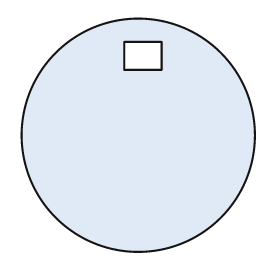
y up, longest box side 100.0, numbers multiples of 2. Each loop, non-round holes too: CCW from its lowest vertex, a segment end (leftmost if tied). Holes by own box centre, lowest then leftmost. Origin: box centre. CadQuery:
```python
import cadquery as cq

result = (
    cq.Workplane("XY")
    .moveTo(0.0, 0.0)
    .circle(50.0)
    .moveTo(-6.0, 28.0)
    .lineTo(10.0, 28.0)
    .lineTo(10.0, 40.0)
    .lineTo(-6.0, 40.0)
    .close()
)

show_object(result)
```